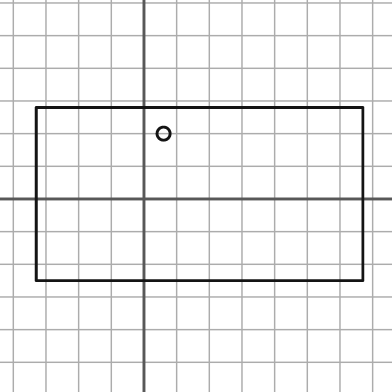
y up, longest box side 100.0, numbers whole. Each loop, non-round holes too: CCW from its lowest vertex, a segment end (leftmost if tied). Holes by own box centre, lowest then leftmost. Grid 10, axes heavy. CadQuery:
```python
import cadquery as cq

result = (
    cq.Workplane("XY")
    .moveTo(-33.0, -25.0)
    .lineTo(67.0, -25.0)
    .lineTo(67.0, 28.0)
    .lineTo(-33.0, 28.0)
    .close()
    .moveTo(6.0, 20.0)
    .circle(2.0)
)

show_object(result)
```